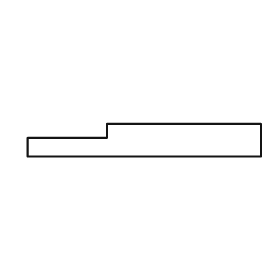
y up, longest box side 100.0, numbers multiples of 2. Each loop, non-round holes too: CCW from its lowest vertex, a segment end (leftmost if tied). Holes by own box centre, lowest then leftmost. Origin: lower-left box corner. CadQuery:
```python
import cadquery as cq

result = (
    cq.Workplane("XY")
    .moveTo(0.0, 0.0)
    .lineTo(100.0, 0.0)
    .lineTo(100.0, 14.0)
    .lineTo(34.0, 14.0)
    .lineTo(34.0, 8.0)
    .lineTo(0.0, 8.0)
    .close()
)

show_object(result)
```